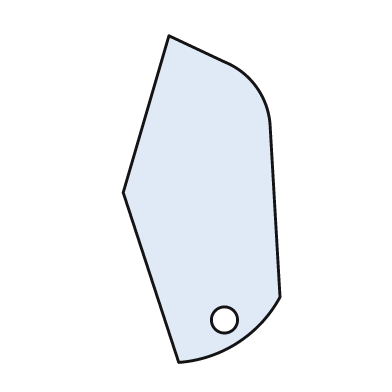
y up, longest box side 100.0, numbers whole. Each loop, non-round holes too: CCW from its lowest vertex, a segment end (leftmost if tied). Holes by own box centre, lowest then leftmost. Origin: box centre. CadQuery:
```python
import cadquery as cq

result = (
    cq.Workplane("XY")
    .moveTo(-7.0, -50.0)
    .threePointArc((11.0, -44.0), (24.0, -30.0))
    .lineTo(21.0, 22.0)
    .threePointArc((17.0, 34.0), (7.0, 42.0))
    .lineTo(-10.0, 50.0)
    .lineTo(-24.0, 2.0)
    .close()
    .moveTo(7.0, -37.0)
    .circle(4.0)
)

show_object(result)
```